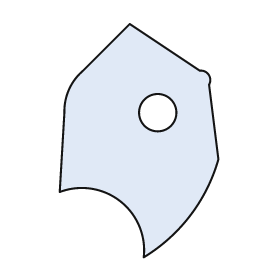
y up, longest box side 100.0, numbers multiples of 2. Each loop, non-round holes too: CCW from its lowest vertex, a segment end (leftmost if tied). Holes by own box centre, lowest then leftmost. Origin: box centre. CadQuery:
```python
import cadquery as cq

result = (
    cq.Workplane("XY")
    .moveTo(2.0, -50.0)
    .threePointArc((22.0, -32.0), (34.0, -8.0))
    .lineTo(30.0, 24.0)
    .threePointArc((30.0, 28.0), (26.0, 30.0))
    .lineTo(-4.0, 50.0)
    .lineTo(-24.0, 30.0)
    .threePointArc((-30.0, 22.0), (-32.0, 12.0))
    .lineTo(-34.0, -22.0)
    .threePointArc((-8.0, -26.0), (2.0, -50.0))
    .close()
    .moveTo(8.0, 12.0)
    .circle(8.0)
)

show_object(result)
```